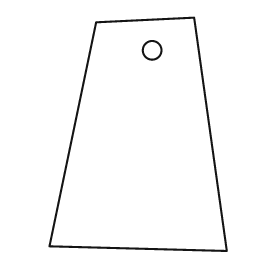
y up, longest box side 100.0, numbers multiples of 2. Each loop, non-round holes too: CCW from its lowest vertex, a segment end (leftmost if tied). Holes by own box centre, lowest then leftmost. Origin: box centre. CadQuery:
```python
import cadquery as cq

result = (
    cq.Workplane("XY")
    .moveTo(38.0, -50.0)
    .lineTo(24.0, 50.0)
    .lineTo(-18.0, 48.0)
    .lineTo(-38.0, -48.0)
    .close()
    .moveTo(6.0, 36.0)
    .circle(4.0)
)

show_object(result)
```